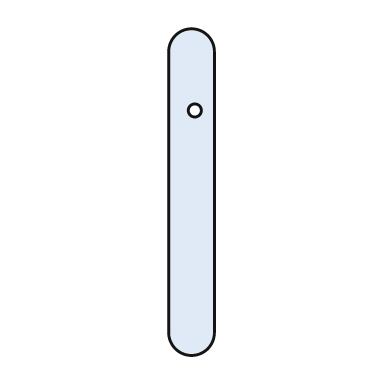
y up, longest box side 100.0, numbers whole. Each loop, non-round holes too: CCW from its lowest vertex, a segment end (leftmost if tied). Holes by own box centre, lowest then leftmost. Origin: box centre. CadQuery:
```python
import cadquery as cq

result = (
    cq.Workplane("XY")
    .moveTo(-7.0, -43.0)
    .threePointArc((0.0, -50.0), (7.0, -43.0))
    .lineTo(7.0, 43.0)
    .threePointArc((0.0, 50.0), (-7.0, 43.0))
    .close()
    .moveTo(1.0, 25.0)
    .circle(2.0)
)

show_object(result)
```